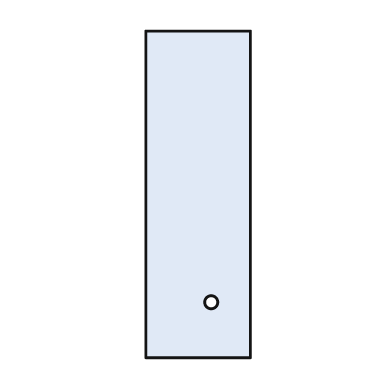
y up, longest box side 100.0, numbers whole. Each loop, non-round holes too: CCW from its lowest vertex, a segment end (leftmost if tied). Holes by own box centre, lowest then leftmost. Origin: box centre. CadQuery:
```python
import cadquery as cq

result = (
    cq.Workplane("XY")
    .moveTo(-16.0, -50.0)
    .lineTo(16.0, -50.0)
    .lineTo(16.0, 50.0)
    .lineTo(-16.0, 50.0)
    .close()
    .moveTo(4.0, -33.0)
    .circle(2.0)
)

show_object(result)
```